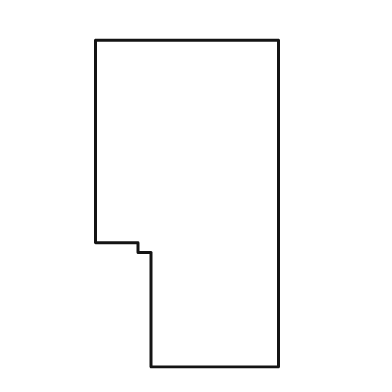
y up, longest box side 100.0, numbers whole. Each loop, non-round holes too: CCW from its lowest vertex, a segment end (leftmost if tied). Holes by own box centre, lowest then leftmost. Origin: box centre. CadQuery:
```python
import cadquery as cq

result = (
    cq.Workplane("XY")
    .moveTo(-11.0, -50.0)
    .lineTo(28.0, -50.0)
    .lineTo(28.0, 50.0)
    .lineTo(-28.0, 50.0)
    .lineTo(-28.0, -12.0)
    .lineTo(-15.0, -12.0)
    .lineTo(-15.0, -15.0)
    .lineTo(-11.0, -15.0)
    .close()
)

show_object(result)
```